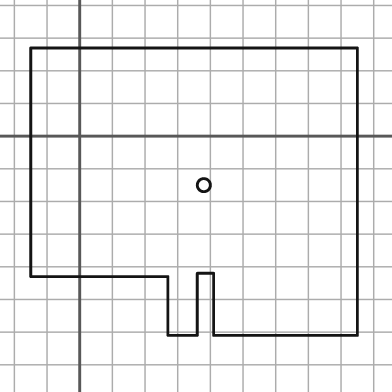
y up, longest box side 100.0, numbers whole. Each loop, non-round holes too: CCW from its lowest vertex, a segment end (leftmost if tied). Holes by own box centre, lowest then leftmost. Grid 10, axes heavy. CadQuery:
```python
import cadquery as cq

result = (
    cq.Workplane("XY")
    .moveTo(27.0, -61.0)
    .lineTo(36.0, -61.0)
    .lineTo(36.0, -42.0)
    .lineTo(41.0, -42.0)
    .lineTo(41.0, -61.0)
    .lineTo(85.0, -61.0)
    .lineTo(85.0, 27.0)
    .lineTo(-15.0, 27.0)
    .lineTo(-15.0, -43.0)
    .lineTo(27.0, -43.0)
    .close()
    .moveTo(38.0, -15.0)
    .circle(2.0)
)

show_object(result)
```